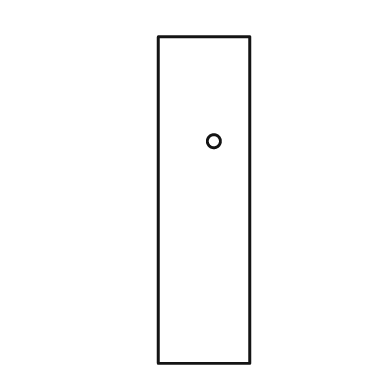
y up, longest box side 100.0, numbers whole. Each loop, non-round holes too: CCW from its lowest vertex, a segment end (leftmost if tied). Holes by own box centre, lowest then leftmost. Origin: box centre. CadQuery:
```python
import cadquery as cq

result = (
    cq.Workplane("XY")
    .moveTo(-14.0, -50.0)
    .lineTo(14.0, -50.0)
    .lineTo(14.0, 50.0)
    .lineTo(-14.0, 50.0)
    .close()
    .moveTo(3.0, 18.0)
    .circle(2.0)
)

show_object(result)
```